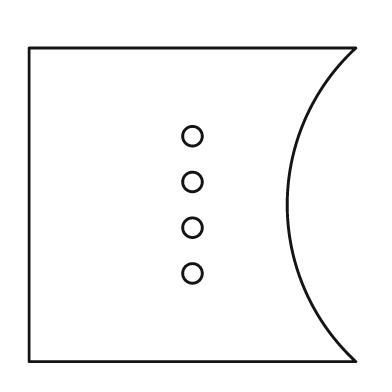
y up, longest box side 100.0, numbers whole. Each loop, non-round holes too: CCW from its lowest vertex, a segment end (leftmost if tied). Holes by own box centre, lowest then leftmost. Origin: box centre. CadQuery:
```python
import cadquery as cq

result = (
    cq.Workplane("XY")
    .moveTo(-50.0, -48.0)
    .lineTo(50.0, -48.0)
    .threePointArc((29.0, 0.0), (50.0, 48.0))
    .lineTo(-50.0, 48.0)
    .close()
    .moveTo(0.0, -21.0)
    .circle(3.0)
    .moveTo(0.0, -7.0)
    .circle(3.0)
    .moveTo(0.0, 7.0)
    .circle(3.0)
    .moveTo(0.0, 21.0)
    .circle(3.0)
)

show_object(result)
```